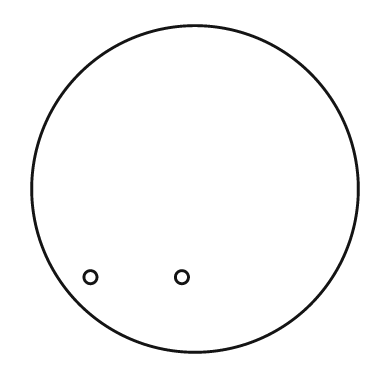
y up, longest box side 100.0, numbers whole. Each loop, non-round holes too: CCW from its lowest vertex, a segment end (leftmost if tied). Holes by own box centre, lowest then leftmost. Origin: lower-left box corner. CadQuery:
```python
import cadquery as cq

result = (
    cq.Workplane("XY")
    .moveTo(50.0, 50.0)
    .circle(50.0)
    .moveTo(18.0, 23.0)
    .circle(2.0)
    .moveTo(46.0, 23.0)
    .circle(2.0)
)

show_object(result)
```